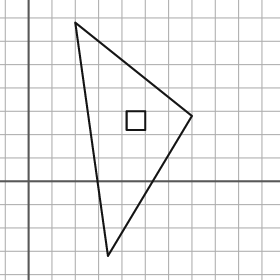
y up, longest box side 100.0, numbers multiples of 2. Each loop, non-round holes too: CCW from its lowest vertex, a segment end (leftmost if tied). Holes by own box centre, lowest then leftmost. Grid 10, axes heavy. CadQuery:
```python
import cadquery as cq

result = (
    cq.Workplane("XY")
    .moveTo(34.0, -32.0)
    .lineTo(70.0, 28.0)
    .lineTo(20.0, 68.0)
    .close()
    .moveTo(42.0, 22.0)
    .lineTo(50.0, 22.0)
    .lineTo(50.0, 30.0)
    .lineTo(42.0, 30.0)
    .close()
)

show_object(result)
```